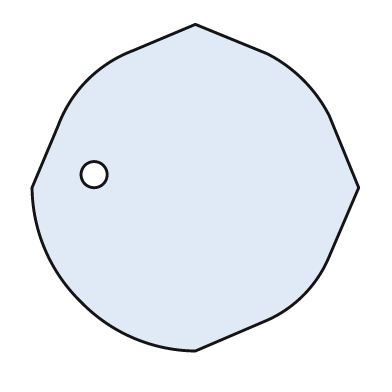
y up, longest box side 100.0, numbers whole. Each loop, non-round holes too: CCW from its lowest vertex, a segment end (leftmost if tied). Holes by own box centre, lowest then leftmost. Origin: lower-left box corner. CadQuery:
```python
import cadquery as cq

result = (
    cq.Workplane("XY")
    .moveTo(50.0, 0.0)
    .lineTo(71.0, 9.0)
    .threePointArc((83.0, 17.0), (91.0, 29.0))
    .lineTo(100.0, 50.0)
    .lineTo(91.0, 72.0)
    .threePointArc((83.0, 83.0), (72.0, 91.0))
    .lineTo(50.0, 100.0)
    .lineTo(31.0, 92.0)
    .threePointArc((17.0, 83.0), (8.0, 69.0))
    .lineTo(0.0, 50.0)
    .threePointArc((4.0, 31.0), (15.0, 15.0))
    .threePointArc((31.0, 4.0), (50.0, 0.0))
    .close()
    .moveTo(19.0, 54.0)
    .circle(4.0)
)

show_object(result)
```